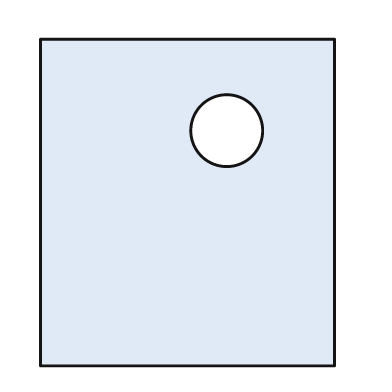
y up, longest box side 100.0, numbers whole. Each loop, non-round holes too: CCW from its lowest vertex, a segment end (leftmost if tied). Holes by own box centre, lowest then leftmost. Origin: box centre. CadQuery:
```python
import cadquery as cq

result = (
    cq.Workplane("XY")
    .moveTo(-45.0, -50.0)
    .lineTo(45.0, -50.0)
    .lineTo(45.0, 50.0)
    .lineTo(-45.0, 50.0)
    .close()
    .moveTo(12.0, 22.0)
    .circle(11.0)
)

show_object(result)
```